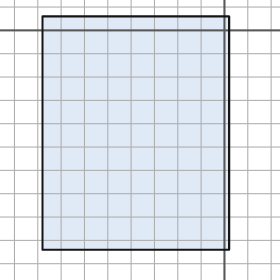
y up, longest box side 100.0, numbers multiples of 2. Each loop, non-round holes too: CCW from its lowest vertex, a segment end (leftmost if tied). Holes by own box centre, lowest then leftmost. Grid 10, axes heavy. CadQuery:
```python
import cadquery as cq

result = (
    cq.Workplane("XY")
    .moveTo(-78.0, -94.0)
    .lineTo(2.0, -94.0)
    .lineTo(2.0, 6.0)
    .lineTo(-78.0, 6.0)
    .close()
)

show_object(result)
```